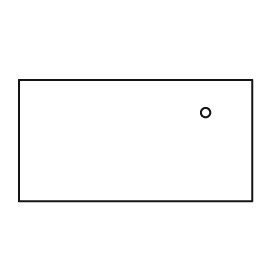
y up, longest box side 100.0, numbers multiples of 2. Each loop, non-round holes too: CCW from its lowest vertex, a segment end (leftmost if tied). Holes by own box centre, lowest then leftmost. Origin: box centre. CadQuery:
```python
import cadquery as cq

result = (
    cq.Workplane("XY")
    .moveTo(-50.0, -26.0)
    .lineTo(50.0, -26.0)
    .lineTo(50.0, 26.0)
    .lineTo(-50.0, 26.0)
    .close()
    .moveTo(30.0, 12.0)
    .circle(2.0)
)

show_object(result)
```